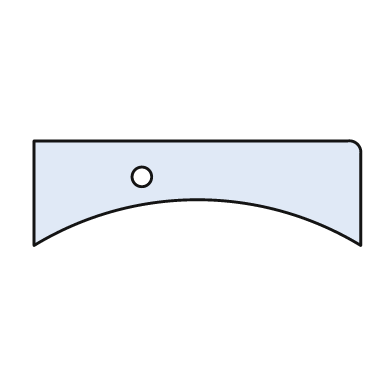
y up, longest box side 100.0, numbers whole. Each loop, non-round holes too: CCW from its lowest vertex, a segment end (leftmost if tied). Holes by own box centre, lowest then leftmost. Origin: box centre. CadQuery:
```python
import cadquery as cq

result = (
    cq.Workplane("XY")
    .moveTo(-50.0, -16.0)
    .threePointArc((0.0, -2.0), (50.0, -16.0))
    .lineTo(50.0, 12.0)
    .threePointArc((49.0, 15.0), (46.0, 16.0))
    .lineTo(-50.0, 16.0)
    .close()
    .moveTo(-17.0, 5.0)
    .circle(3.0)
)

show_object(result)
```